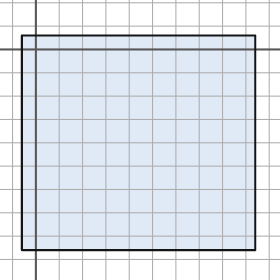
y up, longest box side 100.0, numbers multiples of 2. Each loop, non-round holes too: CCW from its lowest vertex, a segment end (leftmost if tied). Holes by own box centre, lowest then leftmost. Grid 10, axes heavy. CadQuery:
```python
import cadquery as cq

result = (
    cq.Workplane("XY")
    .moveTo(-6.0, -86.0)
    .lineTo(94.0, -86.0)
    .lineTo(94.0, 6.0)
    .lineTo(-6.0, 6.0)
    .close()
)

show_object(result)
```